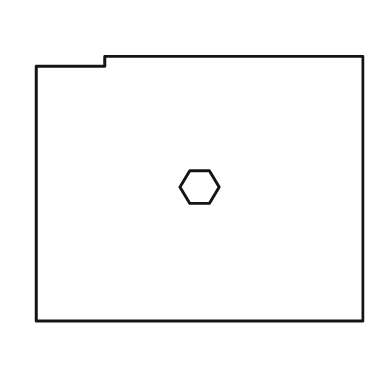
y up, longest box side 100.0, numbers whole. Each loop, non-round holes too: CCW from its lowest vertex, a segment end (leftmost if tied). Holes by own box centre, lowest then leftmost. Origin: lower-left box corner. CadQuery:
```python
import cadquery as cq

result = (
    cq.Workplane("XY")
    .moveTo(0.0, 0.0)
    .lineTo(100.0, 0.0)
    .lineTo(100.0, 81.0)
    .lineTo(21.0, 81.0)
    .lineTo(21.0, 78.0)
    .lineTo(0.0, 78.0)
    .close()
    .moveTo(47.0, 36.0)
    .lineTo(53.0, 36.0)
    .lineTo(56.0, 41.0)
    .lineTo(53.0, 46.0)
    .lineTo(47.0, 46.0)
    .lineTo(44.0, 41.0)
    .close()
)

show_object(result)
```